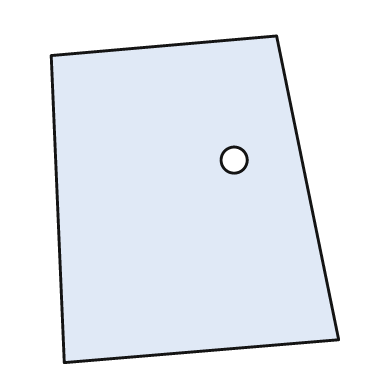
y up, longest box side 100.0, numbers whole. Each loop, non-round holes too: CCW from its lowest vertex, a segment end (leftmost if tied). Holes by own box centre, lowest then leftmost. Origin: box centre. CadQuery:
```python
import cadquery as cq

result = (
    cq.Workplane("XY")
    .moveTo(-40.0, -50.0)
    .lineTo(44.0, -43.0)
    .lineTo(25.0, 50.0)
    .lineTo(-44.0, 44.0)
    .close()
    .moveTo(12.0, 12.0)
    .circle(4.0)
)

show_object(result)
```